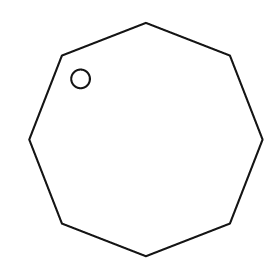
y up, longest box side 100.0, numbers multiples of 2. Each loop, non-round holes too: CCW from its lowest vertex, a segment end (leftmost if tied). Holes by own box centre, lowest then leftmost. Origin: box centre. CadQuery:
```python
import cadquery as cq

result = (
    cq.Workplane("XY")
    .moveTo(0.0, -50.0)
    .lineTo(36.0, -36.0)
    .lineTo(50.0, 0.0)
    .lineTo(36.0, 36.0)
    .lineTo(0.0, 50.0)
    .lineTo(-36.0, 36.0)
    .lineTo(-50.0, 0.0)
    .lineTo(-36.0, -36.0)
    .close()
    .moveTo(-28.0, 26.0)
    .circle(4.0)
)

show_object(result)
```